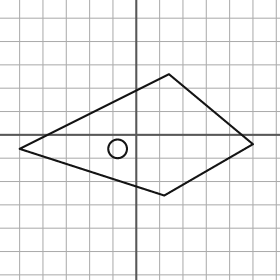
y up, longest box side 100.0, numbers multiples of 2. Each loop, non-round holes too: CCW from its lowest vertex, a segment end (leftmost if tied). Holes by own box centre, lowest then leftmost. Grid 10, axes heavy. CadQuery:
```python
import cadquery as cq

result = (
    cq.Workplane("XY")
    .moveTo(12.0, -26.0)
    .lineTo(50.0, -4.0)
    .lineTo(14.0, 26.0)
    .lineTo(-50.0, -6.0)
    .close()
    .moveTo(-8.0, -6.0)
    .circle(4.0)
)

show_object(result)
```